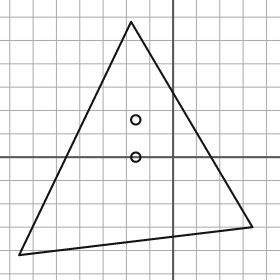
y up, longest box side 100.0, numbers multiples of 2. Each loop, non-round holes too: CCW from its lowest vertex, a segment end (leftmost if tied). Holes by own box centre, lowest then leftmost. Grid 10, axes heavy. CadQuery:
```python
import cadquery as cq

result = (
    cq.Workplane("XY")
    .moveTo(-66.0, -42.0)
    .lineTo(34.0, -30.0)
    .lineTo(-18.0, 58.0)
    .close()
    .moveTo(-16.0, 0.0)
    .circle(2.0)
    .moveTo(-16.0, 16.0)
    .circle(2.0)
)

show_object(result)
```